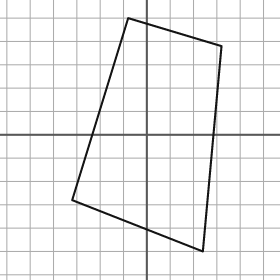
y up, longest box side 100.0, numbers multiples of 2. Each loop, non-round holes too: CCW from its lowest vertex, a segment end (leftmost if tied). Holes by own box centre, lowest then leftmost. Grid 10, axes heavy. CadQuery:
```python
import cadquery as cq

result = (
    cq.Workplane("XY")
    .moveTo(24.0, -50.0)
    .lineTo(32.0, 38.0)
    .lineTo(-8.0, 50.0)
    .lineTo(-32.0, -28.0)
    .close()
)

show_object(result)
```